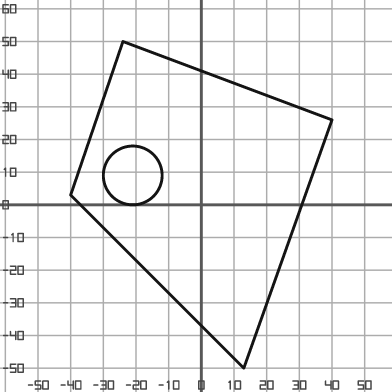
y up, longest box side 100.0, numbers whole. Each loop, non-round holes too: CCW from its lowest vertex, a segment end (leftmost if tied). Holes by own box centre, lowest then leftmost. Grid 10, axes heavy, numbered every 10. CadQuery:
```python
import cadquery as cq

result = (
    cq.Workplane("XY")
    .moveTo(13.0, -50.0)
    .lineTo(40.0, 26.0)
    .lineTo(-24.0, 50.0)
    .lineTo(-40.0, 3.0)
    .close()
    .moveTo(-21.0, 9.0)
    .circle(9.0)
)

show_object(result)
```